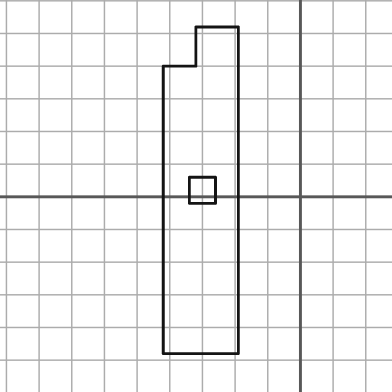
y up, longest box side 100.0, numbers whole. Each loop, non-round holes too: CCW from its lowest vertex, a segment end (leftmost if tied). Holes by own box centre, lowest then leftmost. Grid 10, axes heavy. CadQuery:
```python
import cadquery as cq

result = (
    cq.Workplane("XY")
    .moveTo(-42.0, -48.0)
    .lineTo(-19.0, -48.0)
    .lineTo(-19.0, 52.0)
    .lineTo(-32.0, 52.0)
    .lineTo(-32.0, 40.0)
    .lineTo(-42.0, 40.0)
    .close()
    .moveTo(-34.0, -2.0)
    .lineTo(-26.0, -2.0)
    .lineTo(-26.0, 6.0)
    .lineTo(-34.0, 6.0)
    .close()
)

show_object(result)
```